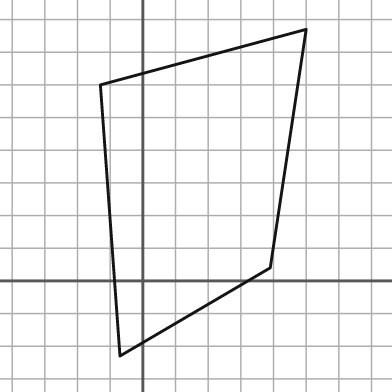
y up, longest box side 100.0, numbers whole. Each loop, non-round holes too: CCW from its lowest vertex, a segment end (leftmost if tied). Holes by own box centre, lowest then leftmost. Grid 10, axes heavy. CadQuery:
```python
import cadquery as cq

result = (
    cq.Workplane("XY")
    .moveTo(-7.0, -23.0)
    .lineTo(39.0, 4.0)
    .lineTo(50.0, 77.0)
    .lineTo(-13.0, 60.0)
    .close()
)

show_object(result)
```